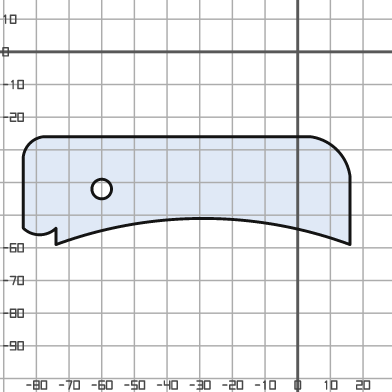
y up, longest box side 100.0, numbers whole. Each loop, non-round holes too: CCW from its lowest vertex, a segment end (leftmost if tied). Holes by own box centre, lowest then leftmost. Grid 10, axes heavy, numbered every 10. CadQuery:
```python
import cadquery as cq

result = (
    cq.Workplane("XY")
    .moveTo(-74.0, -59.0)
    .threePointArc((-29.0, -51.0), (16.0, -59.0))
    .lineTo(16.0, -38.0)
    .threePointArc((12.0, -30.0), (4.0, -26.0))
    .lineTo(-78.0, -26.0)
    .threePointArc((-82.0, -28.0), (-84.0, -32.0))
    .lineTo(-84.0, -54.0)
    .threePointArc((-79.0, -56.0), (-74.0, -54.0))
    .close()
    .moveTo(-60.0, -42.0)
    .circle(3.0)
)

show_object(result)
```